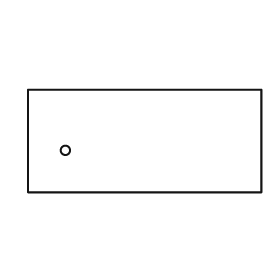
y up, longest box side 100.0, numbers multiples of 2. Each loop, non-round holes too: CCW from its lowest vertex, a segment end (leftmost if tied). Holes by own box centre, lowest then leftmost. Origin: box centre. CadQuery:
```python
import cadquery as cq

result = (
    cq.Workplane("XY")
    .moveTo(-50.0, -22.0)
    .lineTo(50.0, -22.0)
    .lineTo(50.0, 22.0)
    .lineTo(-50.0, 22.0)
    .close()
    .moveTo(-34.0, -4.0)
    .circle(2.0)
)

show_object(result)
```